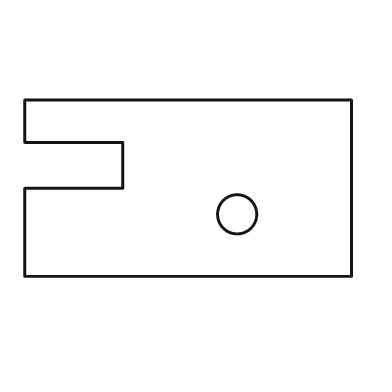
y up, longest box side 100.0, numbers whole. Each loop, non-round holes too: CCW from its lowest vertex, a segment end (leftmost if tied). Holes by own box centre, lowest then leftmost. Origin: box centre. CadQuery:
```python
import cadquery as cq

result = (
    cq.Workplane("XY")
    .moveTo(-50.0, -27.0)
    .lineTo(50.0, -27.0)
    .lineTo(50.0, 27.0)
    .lineTo(-50.0, 27.0)
    .lineTo(-50.0, 14.0)
    .lineTo(-20.0, 14.0)
    .lineTo(-20.0, 0.0)
    .lineTo(-50.0, 0.0)
    .close()
    .moveTo(15.0, -8.0)
    .circle(6.0)
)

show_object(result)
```